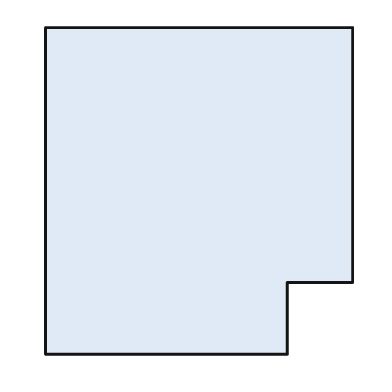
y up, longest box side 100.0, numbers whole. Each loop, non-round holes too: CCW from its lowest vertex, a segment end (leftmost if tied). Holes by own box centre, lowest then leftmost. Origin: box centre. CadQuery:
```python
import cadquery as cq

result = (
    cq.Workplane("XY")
    .moveTo(-47.0, -50.0)
    .lineTo(27.0, -50.0)
    .lineTo(27.0, -28.0)
    .lineTo(47.0, -28.0)
    .lineTo(47.0, 50.0)
    .lineTo(-47.0, 50.0)
    .close()
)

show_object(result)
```